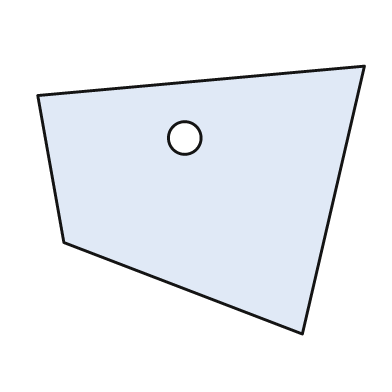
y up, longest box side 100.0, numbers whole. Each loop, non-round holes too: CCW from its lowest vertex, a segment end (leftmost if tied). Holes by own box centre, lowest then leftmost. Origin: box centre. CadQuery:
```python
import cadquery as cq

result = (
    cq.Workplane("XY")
    .moveTo(31.0, -41.0)
    .lineTo(50.0, 41.0)
    .lineTo(-50.0, 32.0)
    .lineTo(-42.0, -13.0)
    .close()
    .moveTo(-5.0, 19.0)
    .circle(5.0)
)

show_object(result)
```